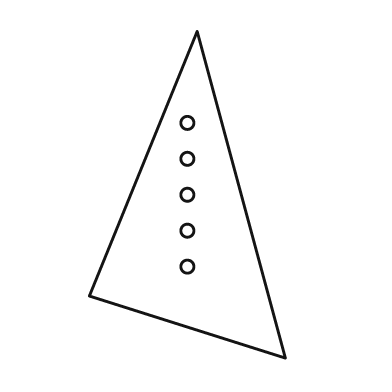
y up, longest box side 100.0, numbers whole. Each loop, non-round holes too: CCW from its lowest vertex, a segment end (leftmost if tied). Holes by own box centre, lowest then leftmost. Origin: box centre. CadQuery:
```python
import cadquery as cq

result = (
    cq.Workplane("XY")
    .moveTo(30.0, -50.0)
    .lineTo(3.0, 50.0)
    .lineTo(-30.0, -31.0)
    .close()
    .moveTo(0.0, -22.0)
    .circle(2.0)
    .moveTo(0.0, -11.0)
    .circle(2.0)
    .moveTo(0.0, 0.0)
    .circle(2.0)
    .moveTo(0.0, 11.0)
    .circle(2.0)
    .moveTo(0.0, 22.0)
    .circle(2.0)
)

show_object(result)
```